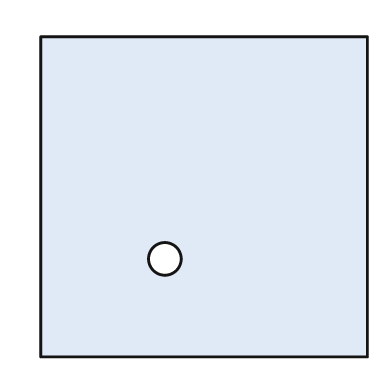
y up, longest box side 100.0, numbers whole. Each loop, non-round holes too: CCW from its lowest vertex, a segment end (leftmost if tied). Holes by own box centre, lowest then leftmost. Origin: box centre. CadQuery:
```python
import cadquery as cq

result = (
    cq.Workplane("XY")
    .moveTo(-50.0, -49.0)
    .lineTo(50.0, -49.0)
    .lineTo(50.0, 49.0)
    .lineTo(-50.0, 49.0)
    .close()
    .moveTo(-12.0, -19.0)
    .circle(5.0)
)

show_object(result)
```